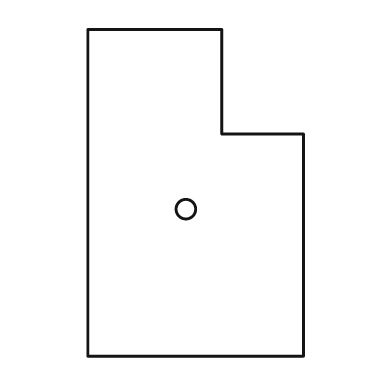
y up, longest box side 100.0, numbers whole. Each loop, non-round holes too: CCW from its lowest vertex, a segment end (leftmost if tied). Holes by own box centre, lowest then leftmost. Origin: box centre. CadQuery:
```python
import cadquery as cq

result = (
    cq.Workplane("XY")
    .moveTo(-33.0, -50.0)
    .lineTo(33.0, -50.0)
    .lineTo(33.0, 18.0)
    .lineTo(8.0, 18.0)
    .lineTo(8.0, 50.0)
    .lineTo(-33.0, 50.0)
    .close()
    .moveTo(-3.0, -5.0)
    .circle(3.0)
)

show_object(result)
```